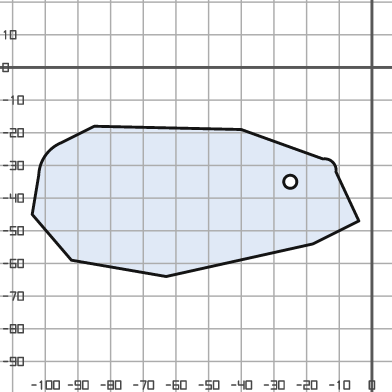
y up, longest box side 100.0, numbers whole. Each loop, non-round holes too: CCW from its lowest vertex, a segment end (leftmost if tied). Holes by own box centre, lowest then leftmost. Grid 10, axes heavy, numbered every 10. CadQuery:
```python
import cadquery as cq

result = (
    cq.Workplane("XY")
    .moveTo(-63.0, -64.0)
    .lineTo(-18.0, -54.0)
    .lineTo(-4.0, -47.0)
    .lineTo(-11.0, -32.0)
    .threePointArc((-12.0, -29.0), (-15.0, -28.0))
    .lineTo(-40.0, -19.0)
    .lineTo(-85.0, -18.0)
    .lineTo(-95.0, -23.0)
    .threePointArc((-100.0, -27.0), (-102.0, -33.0))
    .lineTo(-104.0, -45.0)
    .lineTo(-92.0, -59.0)
    .close()
    .moveTo(-25.0, -35.0)
    .circle(2.0)
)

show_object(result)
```